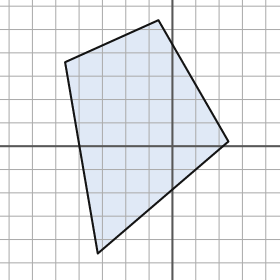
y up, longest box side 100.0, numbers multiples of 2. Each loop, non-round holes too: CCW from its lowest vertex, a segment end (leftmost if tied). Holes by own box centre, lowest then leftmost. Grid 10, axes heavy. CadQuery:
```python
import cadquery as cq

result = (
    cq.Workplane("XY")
    .moveTo(-32.0, -46.0)
    .lineTo(24.0, 2.0)
    .lineTo(-6.0, 54.0)
    .lineTo(-46.0, 36.0)
    .close()
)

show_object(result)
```